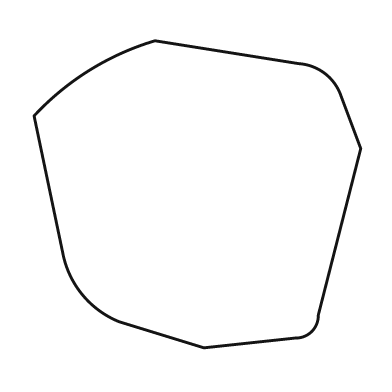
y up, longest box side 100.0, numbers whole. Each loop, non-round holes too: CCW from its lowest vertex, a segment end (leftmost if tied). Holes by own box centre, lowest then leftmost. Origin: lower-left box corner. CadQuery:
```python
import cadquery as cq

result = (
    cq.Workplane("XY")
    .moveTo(52.0, 0.0)
    .lineTo(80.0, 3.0)
    .threePointArc((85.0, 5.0), (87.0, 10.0))
    .lineTo(100.0, 61.0)
    .lineTo(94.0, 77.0)
    .threePointArc((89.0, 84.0), (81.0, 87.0))
    .lineTo(37.0, 94.0)
    .threePointArc((17.0, 85.0), (0.0, 71.0))
    .lineTo(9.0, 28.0)
    .threePointArc((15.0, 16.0), (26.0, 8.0))
    .close()
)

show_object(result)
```